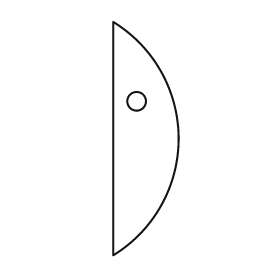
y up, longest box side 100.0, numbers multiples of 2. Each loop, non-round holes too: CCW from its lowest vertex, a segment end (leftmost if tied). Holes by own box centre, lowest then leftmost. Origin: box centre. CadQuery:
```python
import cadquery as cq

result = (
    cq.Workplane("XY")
    .moveTo(-14.0, -50.0)
    .threePointArc((14.0, 0.0), (-14.0, 50.0))
    .close()
    .moveTo(-4.0, 16.0)
    .circle(4.0)
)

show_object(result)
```